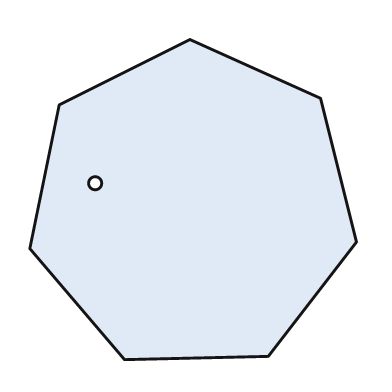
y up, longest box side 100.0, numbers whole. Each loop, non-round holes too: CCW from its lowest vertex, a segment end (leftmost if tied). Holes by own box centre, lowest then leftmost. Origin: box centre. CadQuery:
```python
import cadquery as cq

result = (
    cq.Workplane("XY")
    .moveTo(-21.0, -49.0)
    .lineTo(23.0, -48.0)
    .lineTo(50.0, -13.0)
    .lineTo(39.0, 31.0)
    .lineTo(-1.0, 49.0)
    .lineTo(-41.0, 29.0)
    .lineTo(-50.0, -15.0)
    .close()
    .moveTo(-30.0, 5.0)
    .circle(2.0)
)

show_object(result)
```